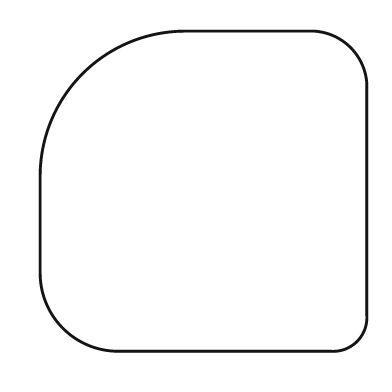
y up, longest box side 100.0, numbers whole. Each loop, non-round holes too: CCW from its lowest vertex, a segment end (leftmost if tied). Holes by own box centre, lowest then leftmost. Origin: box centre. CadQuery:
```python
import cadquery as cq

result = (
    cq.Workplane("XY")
    .moveTo(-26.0, -49.0)
    .lineTo(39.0, -49.0)
    .threePointArc((47.0, -46.0), (50.0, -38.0))
    .lineTo(50.0, 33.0)
    .threePointArc((45.0, 44.0), (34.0, 49.0))
    .lineTo(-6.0, 49.0)
    .threePointArc((-37.0, 36.0), (-50.0, 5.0))
    .lineTo(-50.0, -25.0)
    .threePointArc((-43.0, -42.0), (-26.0, -49.0))
    .close()
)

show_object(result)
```